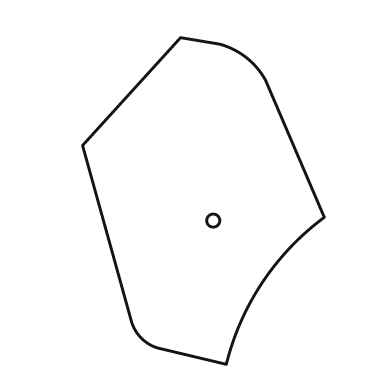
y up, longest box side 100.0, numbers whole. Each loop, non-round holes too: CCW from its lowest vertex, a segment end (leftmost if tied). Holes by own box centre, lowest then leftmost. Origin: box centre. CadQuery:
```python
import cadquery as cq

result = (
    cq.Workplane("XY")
    .moveTo(7.0, -50.0)
    .threePointArc((18.0, -25.0), (37.0, -5.0))
    .lineTo(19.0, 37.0)
    .threePointArc((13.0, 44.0), (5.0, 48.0))
    .lineTo(-7.0, 50.0)
    .lineTo(-37.0, 17.0)
    .lineTo(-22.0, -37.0)
    .threePointArc((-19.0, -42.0), (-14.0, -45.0))
    .close()
    .moveTo(3.0, -6.0)
    .circle(2.0)
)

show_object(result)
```